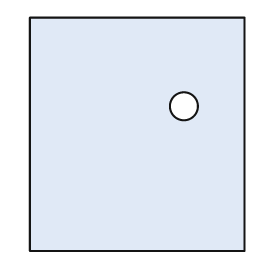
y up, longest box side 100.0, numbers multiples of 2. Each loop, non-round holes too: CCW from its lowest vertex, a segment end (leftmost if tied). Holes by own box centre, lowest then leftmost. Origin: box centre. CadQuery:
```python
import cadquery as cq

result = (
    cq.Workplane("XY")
    .moveTo(-46.0, -50.0)
    .lineTo(46.0, -50.0)
    .lineTo(46.0, 50.0)
    .lineTo(-46.0, 50.0)
    .close()
    .moveTo(20.0, 12.0)
    .circle(6.0)
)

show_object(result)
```